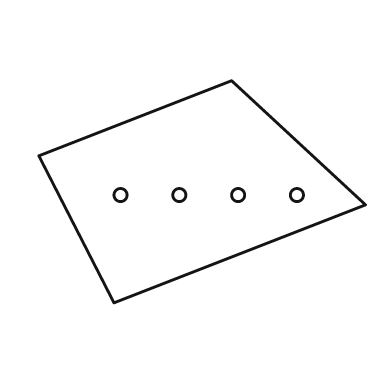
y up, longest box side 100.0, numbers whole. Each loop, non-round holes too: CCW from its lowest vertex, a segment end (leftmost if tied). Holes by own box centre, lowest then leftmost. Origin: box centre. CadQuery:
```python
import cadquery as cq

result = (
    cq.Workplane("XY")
    .moveTo(-27.0, -34.0)
    .lineTo(50.0, -4.0)
    .lineTo(9.0, 34.0)
    .lineTo(-50.0, 11.0)
    .close()
    .moveTo(-25.0, -1.0)
    .circle(2.0)
    .moveTo(-7.0, -1.0)
    .circle(2.0)
    .moveTo(11.0, -1.0)
    .circle(2.0)
    .moveTo(29.0, -1.0)
    .circle(2.0)
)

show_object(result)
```